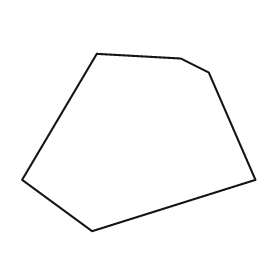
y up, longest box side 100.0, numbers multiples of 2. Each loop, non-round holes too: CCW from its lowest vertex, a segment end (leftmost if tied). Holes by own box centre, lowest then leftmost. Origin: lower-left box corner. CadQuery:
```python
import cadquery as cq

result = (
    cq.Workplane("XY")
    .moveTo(30.0, 0.0)
    .lineTo(100.0, 22.0)
    .lineTo(80.0, 68.0)
    .lineTo(68.0, 74.0)
    .lineTo(32.0, 76.0)
    .lineTo(0.0, 22.0)
    .close()
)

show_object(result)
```